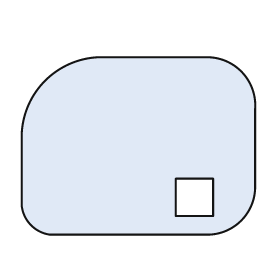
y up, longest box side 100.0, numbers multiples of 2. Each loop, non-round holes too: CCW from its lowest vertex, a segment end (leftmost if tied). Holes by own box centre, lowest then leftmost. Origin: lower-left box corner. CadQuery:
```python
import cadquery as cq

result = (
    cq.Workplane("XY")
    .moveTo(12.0, 0.0)
    .lineTo(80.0, 0.0)
    .threePointArc((94.0, 6.0), (100.0, 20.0))
    .lineTo(100.0, 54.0)
    .threePointArc((94.0, 70.0), (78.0, 76.0))
    .lineTo(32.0, 76.0)
    .threePointArc((10.0, 66.0), (0.0, 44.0))
    .lineTo(0.0, 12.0)
    .threePointArc((4.0, 4.0), (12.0, 0.0))
    .close()
    .moveTo(66.0, 8.0)
    .lineTo(82.0, 8.0)
    .lineTo(82.0, 24.0)
    .lineTo(66.0, 24.0)
    .close()
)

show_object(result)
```